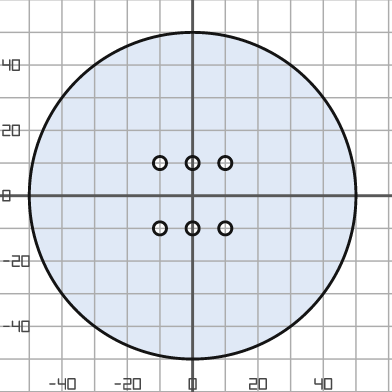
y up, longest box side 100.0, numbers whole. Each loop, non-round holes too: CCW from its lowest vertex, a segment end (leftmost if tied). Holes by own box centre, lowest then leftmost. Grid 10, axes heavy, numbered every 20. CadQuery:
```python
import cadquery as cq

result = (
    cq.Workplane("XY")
    .moveTo(0.0, 0.0)
    .circle(50.0)
    .moveTo(-10.0, -10.0)
    .circle(2.0)
    .moveTo(0.0, -10.0)
    .circle(2.0)
    .moveTo(10.0, -10.0)
    .circle(2.0)
    .moveTo(-10.0, 10.0)
    .circle(2.0)
    .moveTo(0.0, 10.0)
    .circle(2.0)
    .moveTo(10.0, 10.0)
    .circle(2.0)
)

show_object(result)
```